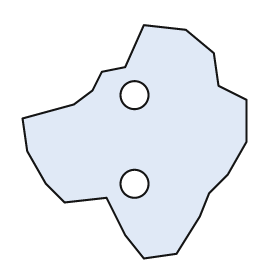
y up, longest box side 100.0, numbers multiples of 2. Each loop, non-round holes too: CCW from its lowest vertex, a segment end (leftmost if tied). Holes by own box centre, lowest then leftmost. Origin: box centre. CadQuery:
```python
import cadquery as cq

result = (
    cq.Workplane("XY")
    .moveTo(4.0, -50.0)
    .lineTo(18.0, -48.0)
    .lineTo(28.0, -32.0)
    .lineTo(32.0, -22.0)
    .lineTo(40.0, -14.0)
    .lineTo(48.0, 0.0)
    .lineTo(48.0, 18.0)
    .lineTo(36.0, 24.0)
    .lineTo(34.0, 38.0)
    .lineTo(22.0, 48.0)
    .lineTo(4.0, 50.0)
    .lineTo(-4.0, 32.0)
    .lineTo(-14.0, 30.0)
    .lineTo(-18.0, 22.0)
    .lineTo(-26.0, 16.0)
    .lineTo(-48.0, 10.0)
    .lineTo(-46.0, -4.0)
    .lineTo(-38.0, -18.0)
    .lineTo(-30.0, -26.0)
    .lineTo(-12.0, -24.0)
    .lineTo(-4.0, -40.0)
    .close()
    .moveTo(0.0, -18.0)
    .circle(6.0)
    .moveTo(0.0, 20.0)
    .circle(6.0)
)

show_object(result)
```